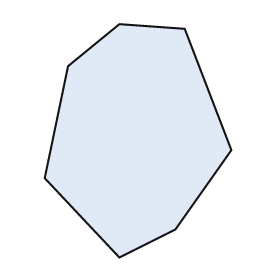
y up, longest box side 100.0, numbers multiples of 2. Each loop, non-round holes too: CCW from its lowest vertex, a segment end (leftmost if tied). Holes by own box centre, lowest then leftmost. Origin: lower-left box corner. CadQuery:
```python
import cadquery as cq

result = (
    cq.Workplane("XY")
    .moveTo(32.0, 0.0)
    .lineTo(56.0, 12.0)
    .lineTo(80.0, 46.0)
    .lineTo(60.0, 98.0)
    .lineTo(32.0, 100.0)
    .lineTo(10.0, 82.0)
    .lineTo(0.0, 34.0)
    .close()
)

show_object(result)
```